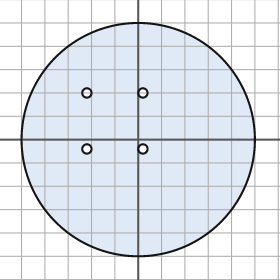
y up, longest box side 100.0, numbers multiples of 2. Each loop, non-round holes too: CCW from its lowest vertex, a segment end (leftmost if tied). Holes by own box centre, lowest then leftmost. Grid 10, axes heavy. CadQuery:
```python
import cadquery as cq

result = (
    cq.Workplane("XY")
    .moveTo(0.0, 0.0)
    .circle(50.0)
    .moveTo(-22.0, -4.0)
    .circle(2.0)
    .moveTo(2.0, -4.0)
    .circle(2.0)
    .moveTo(-22.0, 20.0)
    .circle(2.0)
    .moveTo(2.0, 20.0)
    .circle(2.0)
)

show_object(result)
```